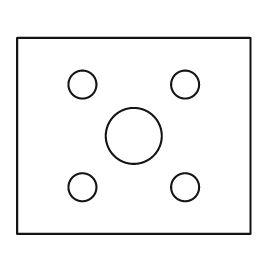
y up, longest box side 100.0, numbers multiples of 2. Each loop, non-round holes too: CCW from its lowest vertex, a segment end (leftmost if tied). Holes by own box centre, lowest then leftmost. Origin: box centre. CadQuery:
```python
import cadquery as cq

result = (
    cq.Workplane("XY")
    .moveTo(-50.0, -42.0)
    .lineTo(50.0, -42.0)
    .lineTo(50.0, 42.0)
    .lineTo(-50.0, 42.0)
    .close()
    .moveTo(-22.0, -22.0)
    .circle(6.0)
    .moveTo(22.0, -22.0)
    .circle(6.0)
    .moveTo(0.0, 0.0)
    .circle(12.0)
    .moveTo(-22.0, 22.0)
    .circle(6.0)
    .moveTo(22.0, 22.0)
    .circle(6.0)
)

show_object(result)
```